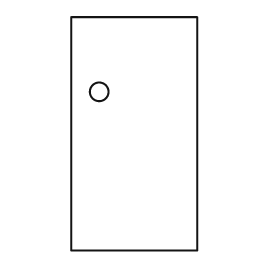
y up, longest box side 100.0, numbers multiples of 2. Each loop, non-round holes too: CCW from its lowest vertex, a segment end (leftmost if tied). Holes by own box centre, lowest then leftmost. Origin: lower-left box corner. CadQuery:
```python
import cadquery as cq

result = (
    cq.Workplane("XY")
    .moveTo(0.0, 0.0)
    .lineTo(54.0, 0.0)
    .lineTo(54.0, 100.0)
    .lineTo(0.0, 100.0)
    .close()
    .moveTo(12.0, 68.0)
    .circle(4.0)
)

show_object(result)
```